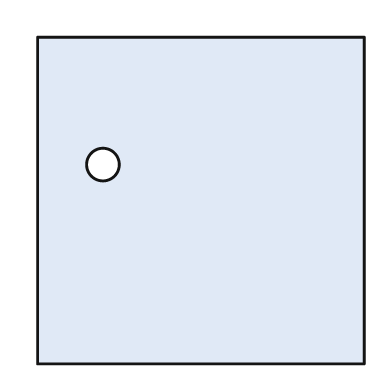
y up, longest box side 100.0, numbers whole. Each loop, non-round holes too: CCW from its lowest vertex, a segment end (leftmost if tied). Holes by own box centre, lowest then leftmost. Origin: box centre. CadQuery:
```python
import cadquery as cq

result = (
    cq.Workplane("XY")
    .moveTo(-50.0, -50.0)
    .lineTo(50.0, -50.0)
    .lineTo(50.0, 50.0)
    .lineTo(-50.0, 50.0)
    .close()
    .moveTo(-30.0, 11.0)
    .circle(5.0)
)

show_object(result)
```